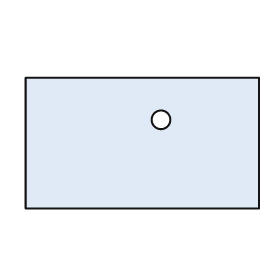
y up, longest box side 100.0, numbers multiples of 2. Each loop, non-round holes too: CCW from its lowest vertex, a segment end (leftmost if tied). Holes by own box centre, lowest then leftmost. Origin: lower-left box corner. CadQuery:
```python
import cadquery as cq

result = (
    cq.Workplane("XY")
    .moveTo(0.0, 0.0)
    .lineTo(100.0, 0.0)
    .lineTo(100.0, 56.0)
    .lineTo(0.0, 56.0)
    .close()
    .moveTo(58.0, 38.0)
    .circle(4.0)
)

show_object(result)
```